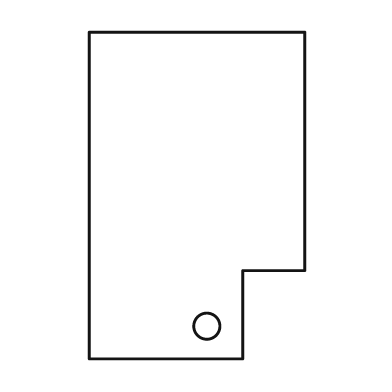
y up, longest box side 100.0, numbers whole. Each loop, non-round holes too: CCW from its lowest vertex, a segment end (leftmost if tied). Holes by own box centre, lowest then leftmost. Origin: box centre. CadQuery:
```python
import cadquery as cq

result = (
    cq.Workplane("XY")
    .moveTo(-33.0, -50.0)
    .lineTo(14.0, -50.0)
    .lineTo(14.0, -23.0)
    .lineTo(33.0, -23.0)
    .lineTo(33.0, 50.0)
    .lineTo(-33.0, 50.0)
    .close()
    .moveTo(3.0, -40.0)
    .circle(4.0)
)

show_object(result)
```